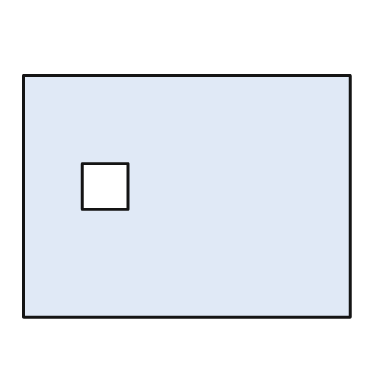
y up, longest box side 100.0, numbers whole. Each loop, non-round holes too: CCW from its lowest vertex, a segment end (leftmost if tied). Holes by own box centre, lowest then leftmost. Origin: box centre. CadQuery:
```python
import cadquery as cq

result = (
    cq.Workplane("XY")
    .moveTo(-50.0, -37.0)
    .lineTo(50.0, -37.0)
    .lineTo(50.0, 37.0)
    .lineTo(-50.0, 37.0)
    .close()
    .moveTo(-32.0, -4.0)
    .lineTo(-18.0, -4.0)
    .lineTo(-18.0, 10.0)
    .lineTo(-32.0, 10.0)
    .close()
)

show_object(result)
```